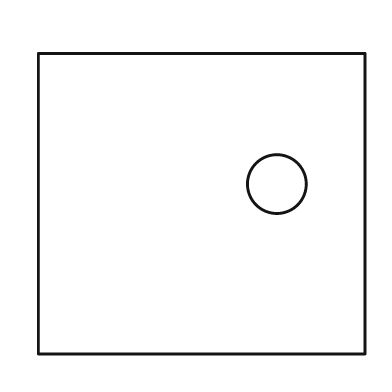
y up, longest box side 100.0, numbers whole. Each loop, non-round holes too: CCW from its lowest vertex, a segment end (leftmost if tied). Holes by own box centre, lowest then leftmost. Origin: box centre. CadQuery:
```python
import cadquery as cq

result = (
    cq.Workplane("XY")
    .moveTo(-50.0, -46.0)
    .lineTo(50.0, -46.0)
    .lineTo(50.0, 46.0)
    .lineTo(-50.0, 46.0)
    .close()
    .moveTo(23.0, 6.0)
    .circle(9.0)
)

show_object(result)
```